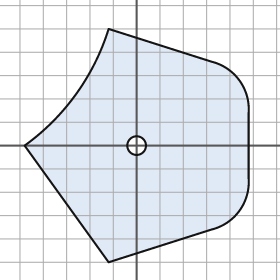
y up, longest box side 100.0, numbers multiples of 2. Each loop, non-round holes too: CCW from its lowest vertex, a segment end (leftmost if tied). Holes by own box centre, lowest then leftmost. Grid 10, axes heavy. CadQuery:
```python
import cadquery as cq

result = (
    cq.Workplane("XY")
    .moveTo(-12.0, -50.0)
    .lineTo(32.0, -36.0)
    .threePointArc((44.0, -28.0), (48.0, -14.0))
    .lineTo(48.0, 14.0)
    .threePointArc((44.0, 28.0), (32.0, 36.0))
    .lineTo(-12.0, 50.0)
    .threePointArc((-26.0, 22.0), (-48.0, 0.0))
    .close()
    .moveTo(0.0, 0.0)
    .circle(4.0)
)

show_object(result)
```